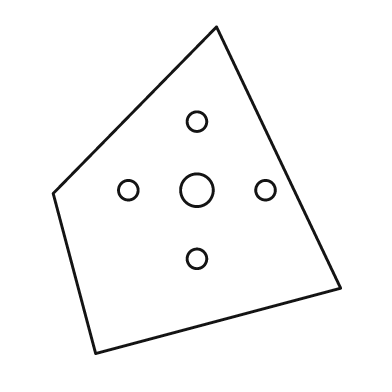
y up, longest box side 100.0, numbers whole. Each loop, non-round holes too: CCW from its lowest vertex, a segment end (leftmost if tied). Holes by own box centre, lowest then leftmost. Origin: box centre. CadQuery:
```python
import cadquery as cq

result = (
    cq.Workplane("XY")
    .moveTo(-31.0, -50.0)
    .lineTo(44.0, -30.0)
    .lineTo(6.0, 50.0)
    .lineTo(-44.0, -1.0)
    .close()
    .moveTo(0.0, -21.0)
    .circle(3.0)
    .moveTo(-21.0, 0.0)
    .circle(3.0)
    .moveTo(0.0, 0.0)
    .circle(5.0)
    .moveTo(21.0, 0.0)
    .circle(3.0)
    .moveTo(0.0, 21.0)
    .circle(3.0)
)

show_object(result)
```